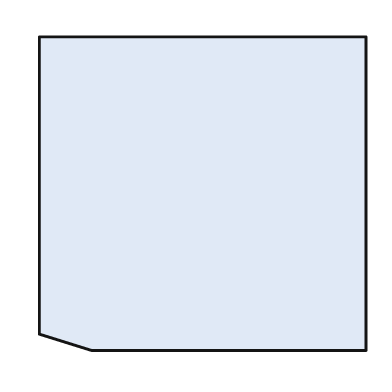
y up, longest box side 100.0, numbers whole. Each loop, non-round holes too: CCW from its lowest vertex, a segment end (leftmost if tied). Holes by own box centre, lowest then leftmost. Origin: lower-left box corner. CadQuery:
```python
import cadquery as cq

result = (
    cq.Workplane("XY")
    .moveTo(16.0, 0.0)
    .lineTo(100.0, 0.0)
    .lineTo(100.0, 96.0)
    .lineTo(0.0, 96.0)
    .lineTo(0.0, 5.0)
    .close()
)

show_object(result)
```